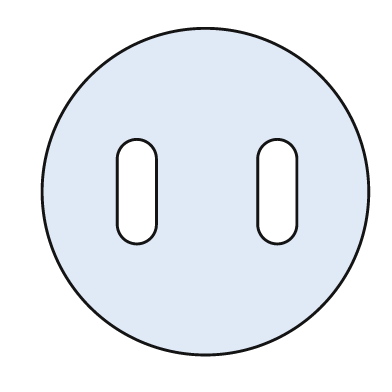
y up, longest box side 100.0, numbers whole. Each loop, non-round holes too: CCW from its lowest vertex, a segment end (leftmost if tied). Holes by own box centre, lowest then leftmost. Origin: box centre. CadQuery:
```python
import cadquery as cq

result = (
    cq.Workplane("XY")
    .moveTo(0.0, 0.0)
    .circle(50.0)
    .moveTo(-27.0, -10.0)
    .threePointArc((-21.0, -16.0), (-15.0, -10.0))
    .lineTo(-15.0, 10.0)
    .threePointArc((-21.0, 16.0), (-27.0, 10.0))
    .close()
    .moveTo(16.0, -10.0)
    .threePointArc((22.0, -16.0), (28.0, -10.0))
    .lineTo(28.0, 10.0)
    .threePointArc((22.0, 16.0), (16.0, 10.0))
    .close()
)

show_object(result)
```